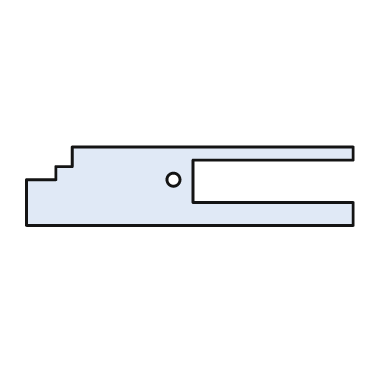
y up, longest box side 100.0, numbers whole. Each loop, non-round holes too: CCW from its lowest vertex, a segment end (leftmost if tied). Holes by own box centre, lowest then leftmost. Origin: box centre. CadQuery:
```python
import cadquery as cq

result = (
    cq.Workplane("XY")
    .moveTo(-50.0, -12.0)
    .lineTo(50.0, -12.0)
    .lineTo(50.0, -5.0)
    .lineTo(1.0, -5.0)
    .lineTo(1.0, 8.0)
    .lineTo(50.0, 8.0)
    .lineTo(50.0, 12.0)
    .lineTo(-36.0, 12.0)
    .lineTo(-36.0, 6.0)
    .lineTo(-41.0, 6.0)
    .lineTo(-41.0, 2.0)
    .lineTo(-50.0, 2.0)
    .close()
    .moveTo(-5.0, 2.0)
    .circle(2.0)
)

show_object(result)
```